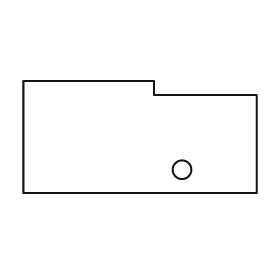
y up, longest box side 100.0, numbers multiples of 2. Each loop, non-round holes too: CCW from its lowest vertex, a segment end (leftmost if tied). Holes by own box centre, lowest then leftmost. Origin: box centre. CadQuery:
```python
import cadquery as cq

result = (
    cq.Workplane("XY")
    .moveTo(-50.0, -24.0)
    .lineTo(50.0, -24.0)
    .lineTo(50.0, 18.0)
    .lineTo(6.0, 18.0)
    .lineTo(6.0, 24.0)
    .lineTo(-50.0, 24.0)
    .close()
    .moveTo(18.0, -14.0)
    .circle(4.0)
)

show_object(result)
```